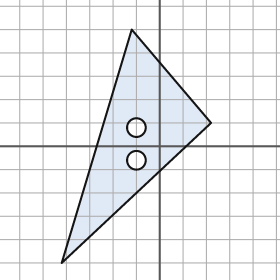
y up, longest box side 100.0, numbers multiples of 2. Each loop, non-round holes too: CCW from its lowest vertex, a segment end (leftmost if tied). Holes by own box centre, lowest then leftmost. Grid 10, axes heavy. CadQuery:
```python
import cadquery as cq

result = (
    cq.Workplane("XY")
    .moveTo(-42.0, -50.0)
    .lineTo(22.0, 10.0)
    .lineTo(-12.0, 50.0)
    .close()
    .moveTo(-10.0, -6.0)
    .circle(4.0)
    .moveTo(-10.0, 8.0)
    .circle(4.0)
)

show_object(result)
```